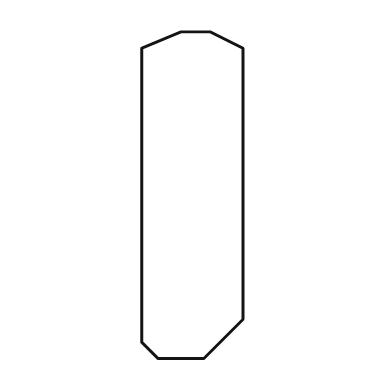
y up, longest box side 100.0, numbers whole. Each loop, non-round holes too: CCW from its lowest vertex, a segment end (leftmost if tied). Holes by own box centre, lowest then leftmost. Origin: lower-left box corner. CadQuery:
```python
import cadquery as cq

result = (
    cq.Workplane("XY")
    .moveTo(5.0, 0.0)
    .lineTo(19.0, 0.0)
    .lineTo(31.0, 12.0)
    .lineTo(31.0, 95.0)
    .lineTo(21.0, 100.0)
    .lineTo(12.0, 100.0)
    .lineTo(0.0, 95.0)
    .lineTo(0.0, 5.0)
    .close()
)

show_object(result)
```